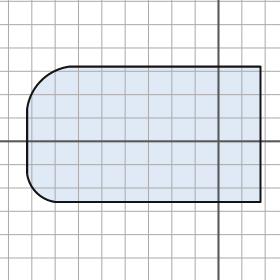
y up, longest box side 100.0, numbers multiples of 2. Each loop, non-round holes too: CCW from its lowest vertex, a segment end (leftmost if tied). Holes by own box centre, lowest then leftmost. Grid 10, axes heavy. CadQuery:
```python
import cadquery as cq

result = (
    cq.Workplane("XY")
    .moveTo(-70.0, -26.0)
    .lineTo(18.0, -26.0)
    .lineTo(18.0, 32.0)
    .lineTo(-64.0, 32.0)
    .threePointArc((-76.0, 26.0), (-82.0, 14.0))
    .lineTo(-82.0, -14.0)
    .threePointArc((-78.0, -22.0), (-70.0, -26.0))
    .close()
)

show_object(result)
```